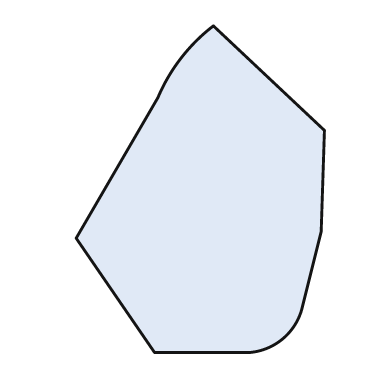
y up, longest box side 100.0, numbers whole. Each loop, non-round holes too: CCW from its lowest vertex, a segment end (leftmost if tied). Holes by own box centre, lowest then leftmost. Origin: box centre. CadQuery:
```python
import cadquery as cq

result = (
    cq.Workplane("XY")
    .moveTo(-14.0, -50.0)
    .lineTo(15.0, -50.0)
    .threePointArc((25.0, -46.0), (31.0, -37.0))
    .lineTo(37.0, -13.0)
    .lineTo(38.0, 18.0)
    .lineTo(4.0, 50.0)
    .threePointArc((-6.0, 40.0), (-13.0, 28.0))
    .lineTo(-38.0, -15.0)
    .close()
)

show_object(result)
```